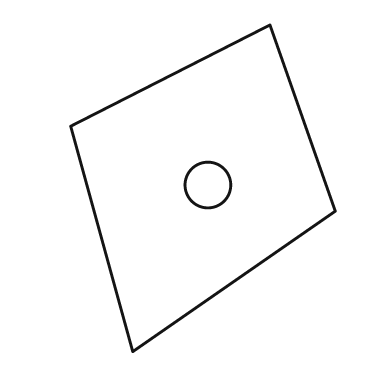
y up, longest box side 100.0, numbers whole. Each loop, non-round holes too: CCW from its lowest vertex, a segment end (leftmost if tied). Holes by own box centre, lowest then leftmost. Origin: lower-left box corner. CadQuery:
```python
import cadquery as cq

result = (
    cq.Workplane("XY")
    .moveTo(19.0, 0.0)
    .lineTo(81.0, 43.0)
    .lineTo(61.0, 100.0)
    .lineTo(0.0, 69.0)
    .close()
    .moveTo(42.0, 51.0)
    .circle(7.0)
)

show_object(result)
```